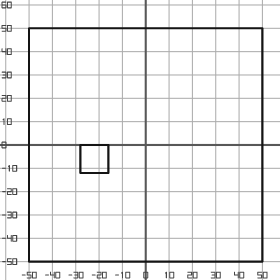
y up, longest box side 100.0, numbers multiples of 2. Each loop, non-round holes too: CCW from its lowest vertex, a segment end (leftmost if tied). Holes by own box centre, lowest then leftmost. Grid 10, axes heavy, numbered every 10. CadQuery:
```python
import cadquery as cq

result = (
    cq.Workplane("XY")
    .moveTo(-50.0, -50.0)
    .lineTo(50.0, -50.0)
    .lineTo(50.0, 50.0)
    .lineTo(-50.0, 50.0)
    .close()
    .moveTo(-28.0, -12.0)
    .lineTo(-16.0, -12.0)
    .lineTo(-16.0, 0.0)
    .lineTo(-28.0, 0.0)
    .close()
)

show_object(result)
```